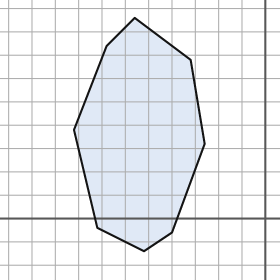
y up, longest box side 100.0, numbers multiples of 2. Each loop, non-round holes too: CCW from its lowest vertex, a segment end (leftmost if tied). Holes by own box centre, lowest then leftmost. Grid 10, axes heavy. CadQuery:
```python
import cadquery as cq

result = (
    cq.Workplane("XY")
    .moveTo(-52.0, -14.0)
    .lineTo(-40.0, -6.0)
    .lineTo(-26.0, 32.0)
    .lineTo(-32.0, 68.0)
    .lineTo(-56.0, 86.0)
    .lineTo(-68.0, 74.0)
    .lineTo(-82.0, 38.0)
    .lineTo(-72.0, -4.0)
    .close()
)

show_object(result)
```